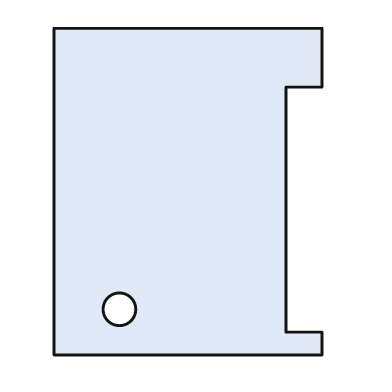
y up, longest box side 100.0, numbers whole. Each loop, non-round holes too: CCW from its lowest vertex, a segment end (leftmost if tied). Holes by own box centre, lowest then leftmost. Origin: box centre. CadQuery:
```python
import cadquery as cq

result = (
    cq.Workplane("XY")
    .moveTo(-41.0, -50.0)
    .lineTo(41.0, -50.0)
    .lineTo(41.0, -43.0)
    .lineTo(30.0, -43.0)
    .lineTo(30.0, 32.0)
    .lineTo(41.0, 32.0)
    .lineTo(41.0, 50.0)
    .lineTo(-41.0, 50.0)
    .close()
    .moveTo(-21.0, -36.0)
    .circle(5.0)
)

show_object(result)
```